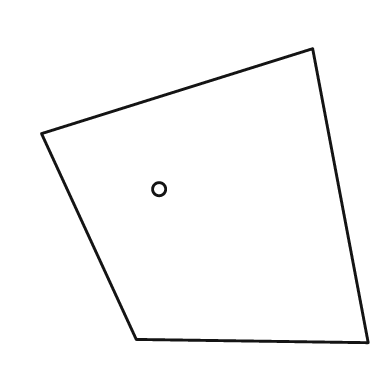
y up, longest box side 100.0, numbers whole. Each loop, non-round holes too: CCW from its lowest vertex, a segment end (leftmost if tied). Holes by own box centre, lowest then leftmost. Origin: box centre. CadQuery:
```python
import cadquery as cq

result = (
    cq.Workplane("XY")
    .moveTo(50.0, -45.0)
    .lineTo(33.0, 45.0)
    .lineTo(-50.0, 19.0)
    .lineTo(-21.0, -44.0)
    .close()
    .moveTo(-14.0, 2.0)
    .circle(2.0)
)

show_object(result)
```